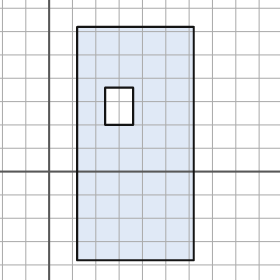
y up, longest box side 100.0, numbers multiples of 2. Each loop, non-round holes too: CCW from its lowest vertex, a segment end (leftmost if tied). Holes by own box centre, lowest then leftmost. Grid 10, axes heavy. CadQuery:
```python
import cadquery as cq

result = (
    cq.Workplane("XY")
    .moveTo(12.0, -38.0)
    .lineTo(62.0, -38.0)
    .lineTo(62.0, 62.0)
    .lineTo(12.0, 62.0)
    .close()
    .moveTo(24.0, 20.0)
    .lineTo(36.0, 20.0)
    .lineTo(36.0, 36.0)
    .lineTo(24.0, 36.0)
    .close()
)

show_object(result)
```